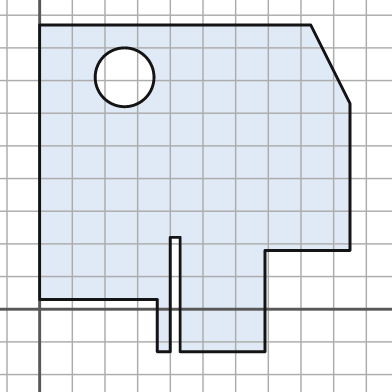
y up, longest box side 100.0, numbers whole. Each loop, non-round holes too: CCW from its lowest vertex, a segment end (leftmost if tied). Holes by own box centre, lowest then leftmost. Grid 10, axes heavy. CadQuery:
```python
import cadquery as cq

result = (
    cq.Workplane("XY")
    .moveTo(36.0, -13.0)
    .lineTo(40.0, -13.0)
    .lineTo(40.0, 22.0)
    .lineTo(43.0, 22.0)
    .lineTo(43.0, -13.0)
    .lineTo(69.0, -13.0)
    .lineTo(69.0, 18.0)
    .lineTo(95.0, 18.0)
    .lineTo(95.0, 63.0)
    .lineTo(83.0, 87.0)
    .lineTo(0.0, 87.0)
    .lineTo(0.0, 3.0)
    .lineTo(36.0, 3.0)
    .close()
    .moveTo(26.0, 71.0)
    .circle(9.0)
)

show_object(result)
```